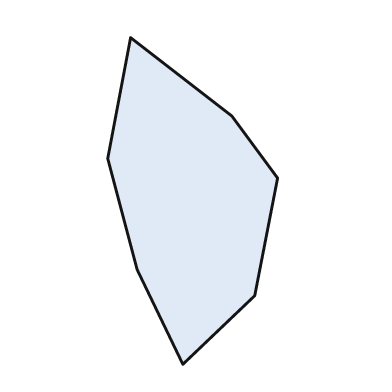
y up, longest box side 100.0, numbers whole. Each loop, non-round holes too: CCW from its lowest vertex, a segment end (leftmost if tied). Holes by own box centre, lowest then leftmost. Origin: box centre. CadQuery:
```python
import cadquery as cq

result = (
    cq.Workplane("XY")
    .moveTo(-3.0, -50.0)
    .lineTo(19.0, -29.0)
    .lineTo(26.0, 7.0)
    .lineTo(12.0, 26.0)
    .lineTo(-19.0, 50.0)
    .lineTo(-26.0, 13.0)
    .lineTo(-17.0, -21.0)
    .close()
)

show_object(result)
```